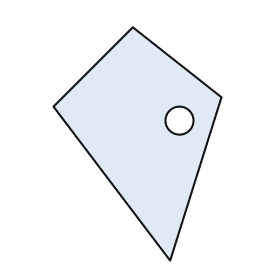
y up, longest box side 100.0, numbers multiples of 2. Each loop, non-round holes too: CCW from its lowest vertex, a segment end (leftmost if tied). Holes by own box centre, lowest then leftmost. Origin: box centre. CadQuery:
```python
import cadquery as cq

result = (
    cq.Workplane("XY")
    .moveTo(14.0, -50.0)
    .lineTo(36.0, 20.0)
    .lineTo(-2.0, 50.0)
    .lineTo(-36.0, 16.0)
    .close()
    .moveTo(18.0, 10.0)
    .circle(6.0)
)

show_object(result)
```